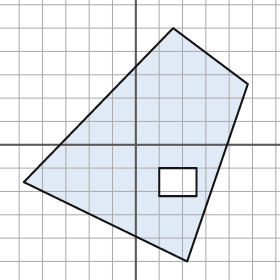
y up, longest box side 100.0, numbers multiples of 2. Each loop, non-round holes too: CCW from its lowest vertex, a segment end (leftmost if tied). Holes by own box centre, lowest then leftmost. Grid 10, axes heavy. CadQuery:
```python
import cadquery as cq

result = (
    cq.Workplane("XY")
    .moveTo(22.0, -50.0)
    .lineTo(48.0, 26.0)
    .lineTo(16.0, 50.0)
    .lineTo(-48.0, -16.0)
    .close()
    .moveTo(10.0, -22.0)
    .lineTo(26.0, -22.0)
    .lineTo(26.0, -10.0)
    .lineTo(10.0, -10.0)
    .close()
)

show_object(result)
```